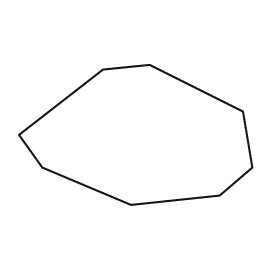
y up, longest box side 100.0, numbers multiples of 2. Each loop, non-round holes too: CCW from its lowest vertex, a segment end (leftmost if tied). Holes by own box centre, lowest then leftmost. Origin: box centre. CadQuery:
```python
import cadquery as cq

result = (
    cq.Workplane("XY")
    .moveTo(-2.0, -30.0)
    .lineTo(36.0, -26.0)
    .lineTo(50.0, -14.0)
    .lineTo(46.0, 10.0)
    .lineTo(6.0, 30.0)
    .lineTo(-14.0, 28.0)
    .lineTo(-50.0, 0.0)
    .lineTo(-40.0, -14.0)
    .close()
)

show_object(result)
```